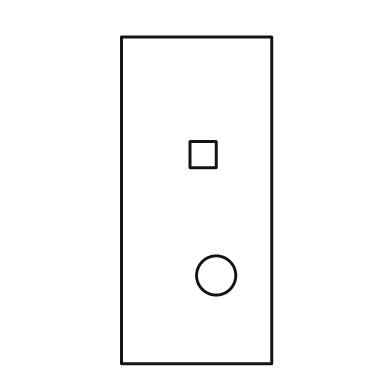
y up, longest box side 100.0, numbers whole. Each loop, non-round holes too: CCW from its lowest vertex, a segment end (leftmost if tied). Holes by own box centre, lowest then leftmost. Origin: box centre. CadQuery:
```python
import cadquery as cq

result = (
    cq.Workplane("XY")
    .moveTo(-23.0, -50.0)
    .lineTo(23.0, -50.0)
    .lineTo(23.0, 50.0)
    .lineTo(-23.0, 50.0)
    .close()
    .moveTo(6.0, -23.0)
    .circle(6.0)
    .moveTo(-2.0, 10.0)
    .lineTo(6.0, 10.0)
    .lineTo(6.0, 18.0)
    .lineTo(-2.0, 18.0)
    .close()
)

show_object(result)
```